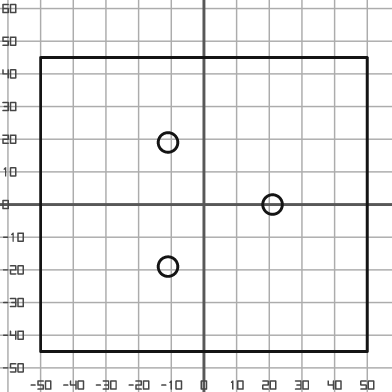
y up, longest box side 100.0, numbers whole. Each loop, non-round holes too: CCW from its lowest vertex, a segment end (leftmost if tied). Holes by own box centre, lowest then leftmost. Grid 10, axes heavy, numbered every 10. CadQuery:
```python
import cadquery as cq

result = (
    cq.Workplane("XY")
    .moveTo(-50.0, -45.0)
    .lineTo(50.0, -45.0)
    .lineTo(50.0, 45.0)
    .lineTo(-50.0, 45.0)
    .close()
    .moveTo(-11.0, -19.0)
    .circle(3.0)
    .moveTo(21.0, 0.0)
    .circle(3.0)
    .moveTo(-11.0, 19.0)
    .circle(3.0)
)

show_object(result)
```